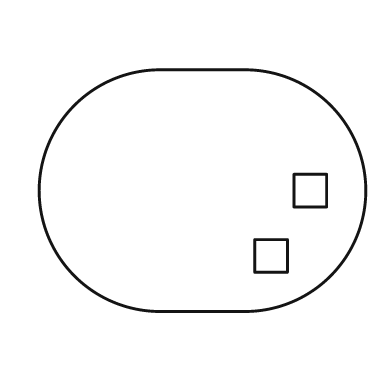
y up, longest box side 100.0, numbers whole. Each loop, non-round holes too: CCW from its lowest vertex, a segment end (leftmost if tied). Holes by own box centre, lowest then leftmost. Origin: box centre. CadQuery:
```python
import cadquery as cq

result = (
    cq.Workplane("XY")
    .moveTo(-13.0, -37.0)
    .lineTo(13.0, -37.0)
    .threePointArc((50.0, 0.0), (13.0, 37.0))
    .lineTo(-13.0, 37.0)
    .threePointArc((-50.0, 0.0), (-13.0, -37.0))
    .close()
    .moveTo(16.0, -25.0)
    .lineTo(26.0, -25.0)
    .lineTo(26.0, -15.0)
    .lineTo(16.0, -15.0)
    .close()
    .moveTo(28.0, -5.0)
    .lineTo(38.0, -5.0)
    .lineTo(38.0, 5.0)
    .lineTo(28.0, 5.0)
    .close()
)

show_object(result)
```